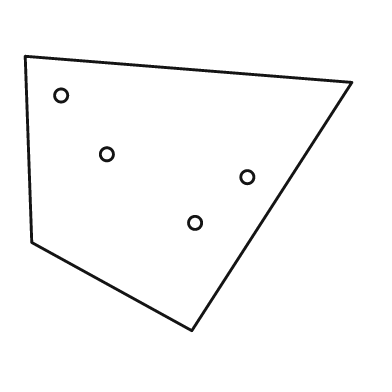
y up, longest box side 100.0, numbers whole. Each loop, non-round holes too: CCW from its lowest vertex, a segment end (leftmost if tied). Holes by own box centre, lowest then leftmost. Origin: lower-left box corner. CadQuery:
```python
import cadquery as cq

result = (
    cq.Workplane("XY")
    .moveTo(51.0, 0.0)
    .lineTo(100.0, 76.0)
    .lineTo(0.0, 84.0)
    .lineTo(2.0, 27.0)
    .close()
    .moveTo(52.0, 33.0)
    .circle(2.0)
    .moveTo(68.0, 47.0)
    .circle(2.0)
    .moveTo(25.0, 54.0)
    .circle(2.0)
    .moveTo(11.0, 72.0)
    .circle(2.0)
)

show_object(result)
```